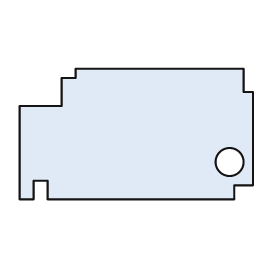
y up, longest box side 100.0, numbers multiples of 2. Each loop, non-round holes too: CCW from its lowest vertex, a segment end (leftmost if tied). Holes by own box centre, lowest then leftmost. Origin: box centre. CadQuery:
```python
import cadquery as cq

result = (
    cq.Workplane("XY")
    .moveTo(-50.0, -28.0)
    .lineTo(-44.0, -28.0)
    .lineTo(-44.0, -20.0)
    .lineTo(-38.0, -20.0)
    .lineTo(-38.0, -28.0)
    .lineTo(42.0, -28.0)
    .lineTo(42.0, -22.0)
    .lineTo(50.0, -22.0)
    .lineTo(50.0, 18.0)
    .lineTo(46.0, 18.0)
    .lineTo(46.0, 28.0)
    .lineTo(-26.0, 28.0)
    .lineTo(-26.0, 24.0)
    .lineTo(-32.0, 24.0)
    .lineTo(-32.0, 12.0)
    .lineTo(-50.0, 12.0)
    .close()
    .moveTo(40.0, -12.0)
    .circle(6.0)
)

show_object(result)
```